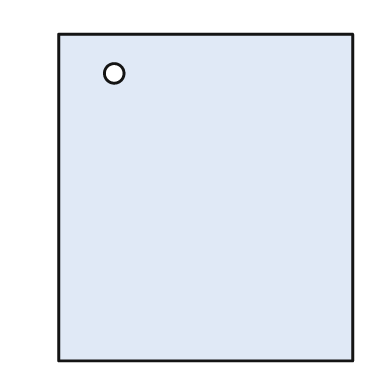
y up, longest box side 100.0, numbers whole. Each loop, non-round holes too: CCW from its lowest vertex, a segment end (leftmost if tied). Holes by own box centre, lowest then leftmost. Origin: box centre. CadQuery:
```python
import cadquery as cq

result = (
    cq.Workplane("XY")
    .moveTo(-45.0, -50.0)
    .lineTo(45.0, -50.0)
    .lineTo(45.0, 50.0)
    .lineTo(-45.0, 50.0)
    .close()
    .moveTo(-28.0, 38.0)
    .circle(3.0)
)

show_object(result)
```